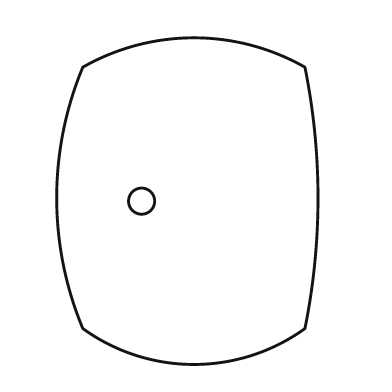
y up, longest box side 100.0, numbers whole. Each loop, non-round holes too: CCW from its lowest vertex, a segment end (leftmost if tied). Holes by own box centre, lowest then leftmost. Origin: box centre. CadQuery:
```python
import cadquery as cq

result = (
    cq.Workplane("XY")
    .moveTo(-32.0, -39.0)
    .threePointArc((2.0, -50.0), (36.0, -39.0))
    .threePointArc((40.0, 1.0), (36.0, 41.0))
    .threePointArc((2.0, 50.0), (-32.0, 41.0))
    .threePointArc((-40.0, 1.0), (-32.0, -39.0))
    .close()
    .moveTo(-14.0, 0.0)
    .circle(4.0)
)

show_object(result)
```